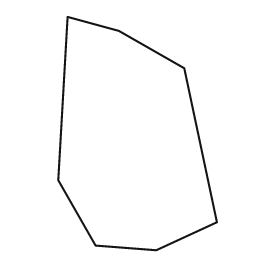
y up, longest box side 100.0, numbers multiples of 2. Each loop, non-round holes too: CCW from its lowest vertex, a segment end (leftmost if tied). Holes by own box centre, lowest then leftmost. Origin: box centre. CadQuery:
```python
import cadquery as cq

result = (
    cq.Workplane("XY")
    .moveTo(8.0, -50.0)
    .lineTo(34.0, -38.0)
    .lineTo(20.0, 28.0)
    .lineTo(-8.0, 44.0)
    .lineTo(-30.0, 50.0)
    .lineTo(-34.0, -20.0)
    .lineTo(-18.0, -48.0)
    .close()
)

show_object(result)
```